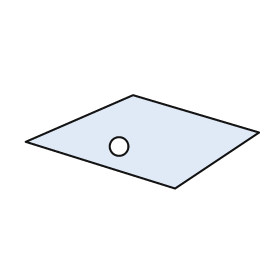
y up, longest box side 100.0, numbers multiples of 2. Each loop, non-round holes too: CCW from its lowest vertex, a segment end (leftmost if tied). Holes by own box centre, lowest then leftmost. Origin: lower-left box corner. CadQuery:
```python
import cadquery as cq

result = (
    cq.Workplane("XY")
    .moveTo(64.0, 0.0)
    .lineTo(100.0, 24.0)
    .lineTo(46.0, 40.0)
    .lineTo(0.0, 20.0)
    .close()
    .moveTo(40.0, 18.0)
    .circle(4.0)
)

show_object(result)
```